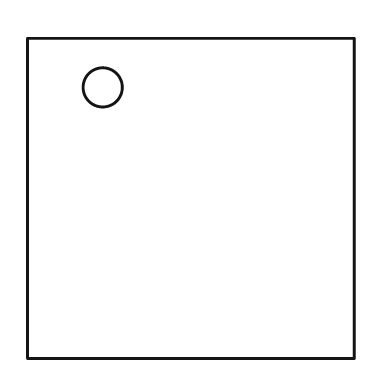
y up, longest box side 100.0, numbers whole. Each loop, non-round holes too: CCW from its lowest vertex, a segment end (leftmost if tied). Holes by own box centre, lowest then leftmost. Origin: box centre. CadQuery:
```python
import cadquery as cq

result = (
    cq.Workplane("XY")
    .moveTo(-50.0, -49.0)
    .lineTo(50.0, -49.0)
    .lineTo(50.0, 49.0)
    .lineTo(-50.0, 49.0)
    .close()
    .moveTo(-27.0, 34.0)
    .circle(6.0)
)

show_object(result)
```